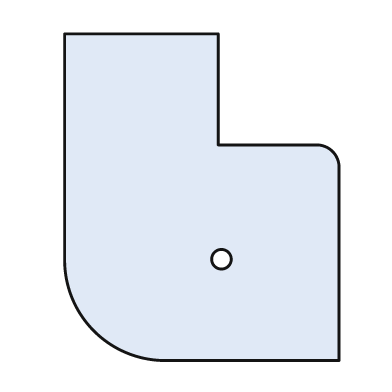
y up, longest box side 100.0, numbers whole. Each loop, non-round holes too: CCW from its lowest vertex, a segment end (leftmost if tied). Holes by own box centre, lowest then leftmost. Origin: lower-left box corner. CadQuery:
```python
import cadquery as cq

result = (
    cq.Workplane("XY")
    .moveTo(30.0, 0.0)
    .lineTo(84.0, 0.0)
    .lineTo(84.0, 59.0)
    .threePointArc((82.0, 64.0), (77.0, 66.0))
    .lineTo(47.0, 66.0)
    .lineTo(47.0, 100.0)
    .lineTo(0.0, 100.0)
    .lineTo(0.0, 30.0)
    .threePointArc((9.0, 9.0), (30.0, 0.0))
    .close()
    .moveTo(48.0, 31.0)
    .circle(3.0)
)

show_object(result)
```